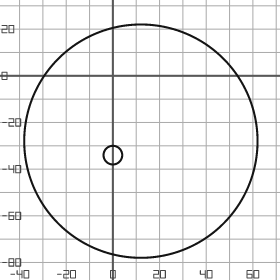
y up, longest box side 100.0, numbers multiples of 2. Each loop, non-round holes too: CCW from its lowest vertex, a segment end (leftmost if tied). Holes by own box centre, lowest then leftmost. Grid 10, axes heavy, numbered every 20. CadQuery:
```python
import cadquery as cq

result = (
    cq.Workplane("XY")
    .moveTo(12.0, -28.0)
    .circle(50.0)
    .moveTo(0.0, -34.0)
    .circle(4.0)
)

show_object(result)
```